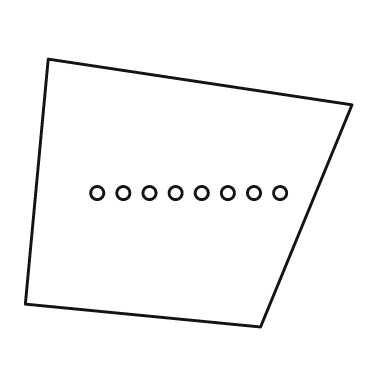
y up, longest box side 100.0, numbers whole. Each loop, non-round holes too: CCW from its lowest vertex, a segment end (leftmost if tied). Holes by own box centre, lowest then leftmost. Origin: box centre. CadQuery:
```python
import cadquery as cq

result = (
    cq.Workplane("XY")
    .moveTo(22.0, -41.0)
    .lineTo(50.0, 27.0)
    .lineTo(-43.0, 41.0)
    .lineTo(-50.0, -34.0)
    .close()
    .moveTo(-28.0, 0.0)
    .circle(2.0)
    .moveTo(-20.0, 0.0)
    .circle(2.0)
    .moveTo(-12.0, 0.0)
    .circle(2.0)
    .moveTo(-4.0, 0.0)
    .circle(2.0)
    .moveTo(4.0, 0.0)
    .circle(2.0)
    .moveTo(12.0, 0.0)
    .circle(2.0)
    .moveTo(20.0, 0.0)
    .circle(2.0)
    .moveTo(28.0, 0.0)
    .circle(2.0)
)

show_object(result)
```